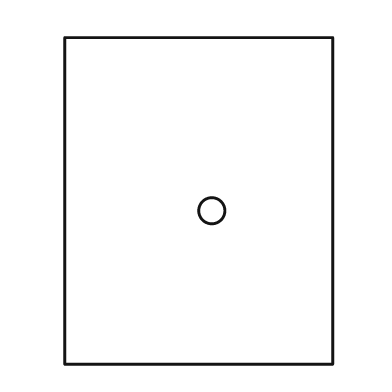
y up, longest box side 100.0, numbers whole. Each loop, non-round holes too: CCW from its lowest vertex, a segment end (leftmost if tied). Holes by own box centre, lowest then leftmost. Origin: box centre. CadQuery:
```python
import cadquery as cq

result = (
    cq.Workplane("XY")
    .moveTo(-41.0, -50.0)
    .lineTo(41.0, -50.0)
    .lineTo(41.0, 50.0)
    .lineTo(-41.0, 50.0)
    .close()
    .moveTo(4.0, -3.0)
    .circle(4.0)
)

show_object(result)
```